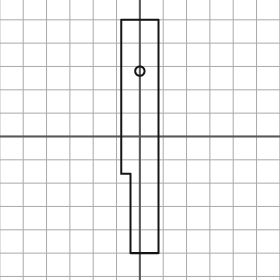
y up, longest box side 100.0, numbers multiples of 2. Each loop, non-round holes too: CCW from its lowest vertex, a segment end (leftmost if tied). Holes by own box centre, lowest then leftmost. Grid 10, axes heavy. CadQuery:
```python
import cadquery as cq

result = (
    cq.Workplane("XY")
    .moveTo(-4.0, -50.0)
    .lineTo(8.0, -50.0)
    .lineTo(8.0, 50.0)
    .lineTo(-8.0, 50.0)
    .lineTo(-8.0, -16.0)
    .lineTo(-4.0, -16.0)
    .close()
    .moveTo(0.0, 28.0)
    .circle(2.0)
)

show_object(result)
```